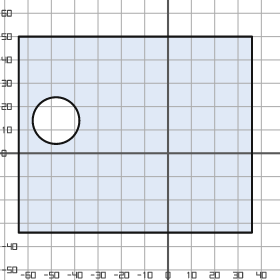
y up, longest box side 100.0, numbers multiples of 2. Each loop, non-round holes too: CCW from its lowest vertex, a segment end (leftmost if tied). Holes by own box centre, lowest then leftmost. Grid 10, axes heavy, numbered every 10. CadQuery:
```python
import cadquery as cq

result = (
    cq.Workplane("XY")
    .moveTo(-64.0, -34.0)
    .lineTo(36.0, -34.0)
    .lineTo(36.0, 50.0)
    .lineTo(-64.0, 50.0)
    .close()
    .moveTo(-48.0, 14.0)
    .circle(10.0)
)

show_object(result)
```